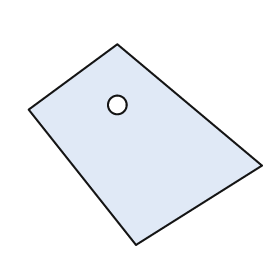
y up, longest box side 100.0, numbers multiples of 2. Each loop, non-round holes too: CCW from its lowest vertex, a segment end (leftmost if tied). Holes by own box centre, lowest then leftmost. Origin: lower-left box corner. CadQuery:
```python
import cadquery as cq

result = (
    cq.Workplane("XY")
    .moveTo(46.0, 0.0)
    .lineTo(100.0, 34.0)
    .lineTo(38.0, 86.0)
    .lineTo(0.0, 58.0)
    .close()
    .moveTo(38.0, 60.0)
    .circle(4.0)
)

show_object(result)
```